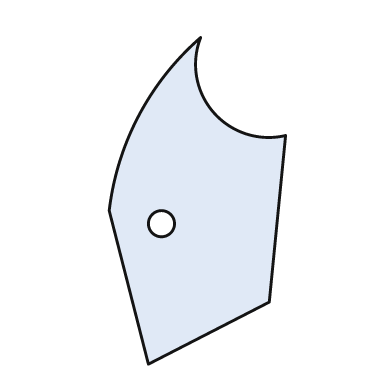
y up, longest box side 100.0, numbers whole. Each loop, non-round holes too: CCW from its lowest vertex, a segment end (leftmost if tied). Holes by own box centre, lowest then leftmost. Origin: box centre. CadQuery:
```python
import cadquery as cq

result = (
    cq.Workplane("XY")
    .moveTo(-15.0, -50.0)
    .lineTo(22.0, -31.0)
    .lineTo(27.0, 20.0)
    .threePointArc((5.0, 27.0), (1.0, 50.0))
    .threePointArc((-18.0, 26.0), (-27.0, -3.0))
    .close()
    .moveTo(-11.0, -7.0)
    .circle(4.0)
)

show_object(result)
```